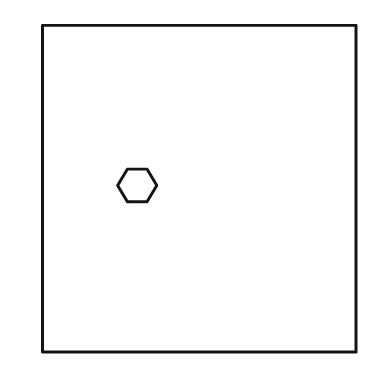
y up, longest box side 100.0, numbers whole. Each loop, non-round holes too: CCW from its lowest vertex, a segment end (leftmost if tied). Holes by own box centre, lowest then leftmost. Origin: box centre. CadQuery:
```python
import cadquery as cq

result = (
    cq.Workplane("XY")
    .moveTo(-48.0, -50.0)
    .lineTo(48.0, -50.0)
    .lineTo(48.0, 50.0)
    .lineTo(-48.0, 50.0)
    .close()
    .moveTo(-22.0, -4.0)
    .lineTo(-16.0, -4.0)
    .lineTo(-13.0, 1.0)
    .lineTo(-16.0, 6.0)
    .lineTo(-22.0, 6.0)
    .lineTo(-25.0, 1.0)
    .close()
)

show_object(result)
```